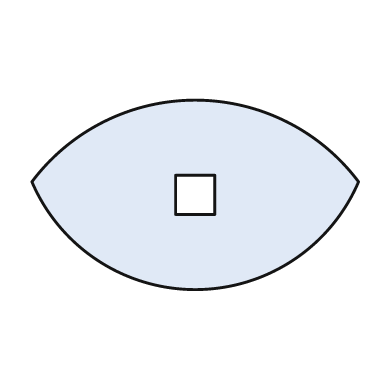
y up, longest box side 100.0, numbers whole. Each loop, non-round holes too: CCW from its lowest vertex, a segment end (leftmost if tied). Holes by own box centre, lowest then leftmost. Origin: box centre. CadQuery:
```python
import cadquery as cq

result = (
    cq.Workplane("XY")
    .moveTo(-50.0, 4.0)
    .threePointArc((0.0, -29.0), (50.0, 4.0))
    .threePointArc((0.0, 29.0), (-50.0, 4.0))
    .close()
    .moveTo(-6.0, -6.0)
    .lineTo(6.0, -6.0)
    .lineTo(6.0, 6.0)
    .lineTo(-6.0, 6.0)
    .close()
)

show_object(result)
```